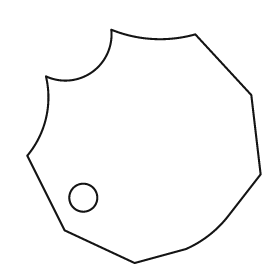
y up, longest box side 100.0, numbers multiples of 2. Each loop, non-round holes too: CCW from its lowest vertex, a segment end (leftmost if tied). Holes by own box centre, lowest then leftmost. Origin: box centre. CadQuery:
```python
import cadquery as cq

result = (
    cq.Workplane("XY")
    .moveTo(-4.0, -50.0)
    .lineTo(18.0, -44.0)
    .threePointArc((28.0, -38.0), (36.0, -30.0))
    .lineTo(50.0, -12.0)
    .lineTo(46.0, 22.0)
    .lineTo(22.0, 48.0)
    .threePointArc((4.0, 46.0), (-14.0, 50.0))
    .threePointArc((-22.0, 32.0), (-42.0, 30.0))
    .threePointArc((-42.0, 12.0), (-50.0, -4.0))
    .lineTo(-34.0, -36.0)
    .close()
    .moveTo(-26.0, -22.0)
    .circle(6.0)
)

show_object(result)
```